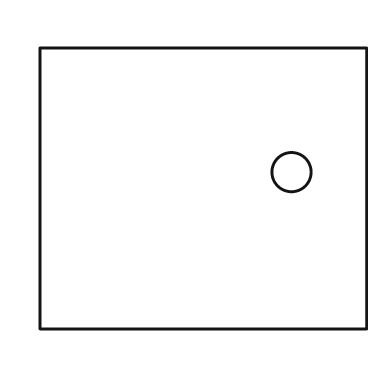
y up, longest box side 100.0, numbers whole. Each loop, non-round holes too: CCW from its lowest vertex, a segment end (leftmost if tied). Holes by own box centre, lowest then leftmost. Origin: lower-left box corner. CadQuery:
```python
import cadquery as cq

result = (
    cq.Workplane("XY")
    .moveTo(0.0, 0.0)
    .lineTo(100.0, 0.0)
    .lineTo(100.0, 86.0)
    .lineTo(0.0, 86.0)
    .close()
    .moveTo(77.0, 48.0)
    .circle(6.0)
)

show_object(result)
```